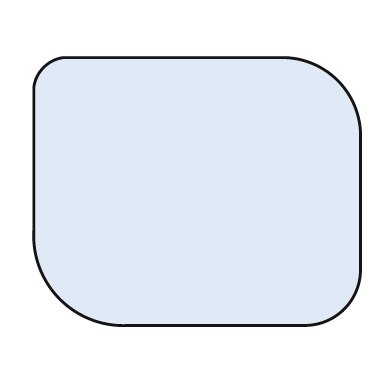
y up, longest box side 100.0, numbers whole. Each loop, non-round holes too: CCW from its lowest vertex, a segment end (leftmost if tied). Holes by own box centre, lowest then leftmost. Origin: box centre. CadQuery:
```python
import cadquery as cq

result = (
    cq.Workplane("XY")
    .moveTo(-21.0, -41.0)
    .lineTo(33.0, -41.0)
    .threePointArc((45.0, -36.0), (50.0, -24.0))
    .lineTo(50.0, 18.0)
    .threePointArc((43.0, 34.0), (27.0, 41.0))
    .lineTo(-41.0, 41.0)
    .threePointArc((-47.0, 38.0), (-50.0, 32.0))
    .lineTo(-50.0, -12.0)
    .threePointArc((-42.0, -33.0), (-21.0, -41.0))
    .close()
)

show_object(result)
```